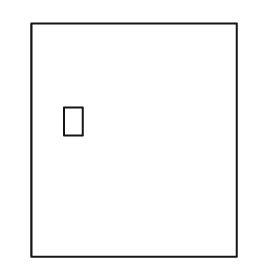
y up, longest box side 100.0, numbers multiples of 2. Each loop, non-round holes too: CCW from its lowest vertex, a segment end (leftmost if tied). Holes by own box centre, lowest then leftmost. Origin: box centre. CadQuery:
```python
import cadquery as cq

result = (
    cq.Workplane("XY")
    .moveTo(-44.0, -50.0)
    .lineTo(44.0, -50.0)
    .lineTo(44.0, 50.0)
    .lineTo(-44.0, 50.0)
    .close()
    .moveTo(-30.0, 2.0)
    .lineTo(-22.0, 2.0)
    .lineTo(-22.0, 14.0)
    .lineTo(-30.0, 14.0)
    .close()
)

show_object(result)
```